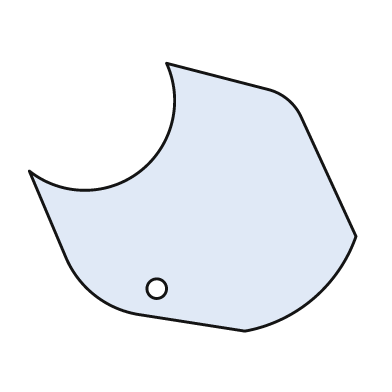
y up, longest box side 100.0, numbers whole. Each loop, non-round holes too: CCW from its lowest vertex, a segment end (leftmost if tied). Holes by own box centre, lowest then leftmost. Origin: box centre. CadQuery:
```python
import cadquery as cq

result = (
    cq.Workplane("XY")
    .moveTo(16.0, -41.0)
    .threePointArc((37.0, -31.0), (50.0, -12.0))
    .lineTo(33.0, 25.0)
    .threePointArc((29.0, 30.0), (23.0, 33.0))
    .lineTo(-8.0, 41.0)
    .threePointArc((-16.0, 8.0), (-50.0, 8.0))
    .lineTo(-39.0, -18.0)
    .threePointArc((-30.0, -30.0), (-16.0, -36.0))
    .close()
    .moveTo(-11.0, -28.0)
    .circle(3.0)
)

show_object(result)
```